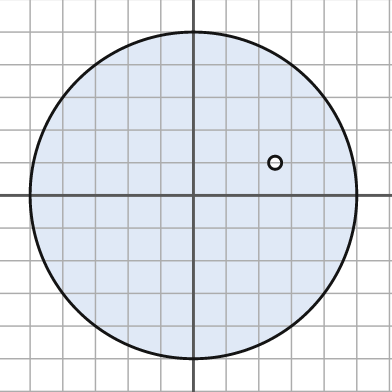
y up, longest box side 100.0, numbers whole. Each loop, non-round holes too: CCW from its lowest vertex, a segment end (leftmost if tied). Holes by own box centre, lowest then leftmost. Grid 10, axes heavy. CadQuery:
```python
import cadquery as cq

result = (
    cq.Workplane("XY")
    .moveTo(0.0, 0.0)
    .circle(50.0)
    .moveTo(25.0, 10.0)
    .circle(2.0)
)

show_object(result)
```